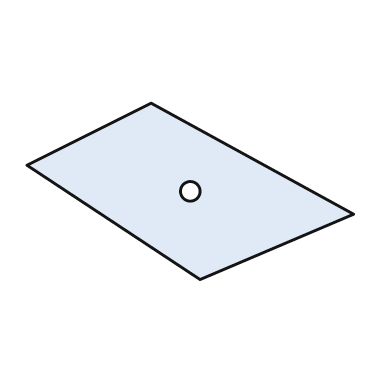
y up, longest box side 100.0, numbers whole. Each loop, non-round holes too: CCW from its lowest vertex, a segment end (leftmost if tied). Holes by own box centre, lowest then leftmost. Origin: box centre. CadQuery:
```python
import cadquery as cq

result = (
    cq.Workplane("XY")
    .moveTo(3.0, -27.0)
    .lineTo(50.0, -7.0)
    .lineTo(-12.0, 27.0)
    .lineTo(-50.0, 8.0)
    .close()
    .moveTo(0.0, 0.0)
    .circle(3.0)
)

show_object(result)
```